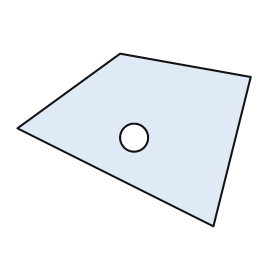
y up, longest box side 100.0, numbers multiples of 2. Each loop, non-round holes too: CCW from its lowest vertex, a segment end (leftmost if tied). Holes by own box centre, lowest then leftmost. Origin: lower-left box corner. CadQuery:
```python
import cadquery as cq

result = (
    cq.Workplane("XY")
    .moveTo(84.0, 0.0)
    .lineTo(100.0, 64.0)
    .lineTo(44.0, 74.0)
    .lineTo(0.0, 42.0)
    .close()
    .moveTo(50.0, 38.0)
    .circle(6.0)
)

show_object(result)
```